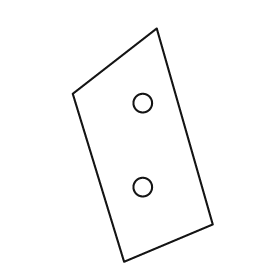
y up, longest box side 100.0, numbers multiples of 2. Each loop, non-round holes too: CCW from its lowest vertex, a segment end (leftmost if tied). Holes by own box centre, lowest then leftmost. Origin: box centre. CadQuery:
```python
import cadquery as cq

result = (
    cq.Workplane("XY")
    .moveTo(-8.0, -50.0)
    .lineTo(30.0, -34.0)
    .lineTo(6.0, 50.0)
    .lineTo(-30.0, 22.0)
    .close()
    .moveTo(0.0, -18.0)
    .circle(4.0)
    .moveTo(0.0, 18.0)
    .circle(4.0)
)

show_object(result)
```